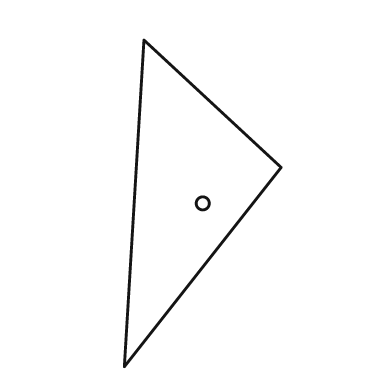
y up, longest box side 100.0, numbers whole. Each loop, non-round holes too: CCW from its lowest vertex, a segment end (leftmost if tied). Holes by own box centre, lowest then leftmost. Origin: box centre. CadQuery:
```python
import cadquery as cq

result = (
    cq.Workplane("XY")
    .moveTo(-24.0, -50.0)
    .lineTo(24.0, 11.0)
    .lineTo(-18.0, 50.0)
    .close()
    .moveTo(0.0, 0.0)
    .circle(2.0)
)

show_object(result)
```